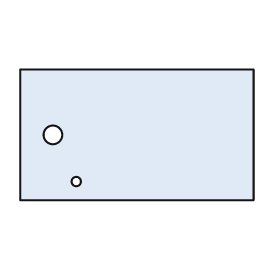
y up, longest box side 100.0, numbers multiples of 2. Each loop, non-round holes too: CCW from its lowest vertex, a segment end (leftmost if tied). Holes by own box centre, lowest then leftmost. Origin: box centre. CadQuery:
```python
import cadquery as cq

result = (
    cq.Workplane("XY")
    .moveTo(-50.0, -28.0)
    .lineTo(50.0, -28.0)
    .lineTo(50.0, 28.0)
    .lineTo(-50.0, 28.0)
    .close()
    .moveTo(-26.0, -20.0)
    .circle(2.0)
    .moveTo(-36.0, 0.0)
    .circle(4.0)
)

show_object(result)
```